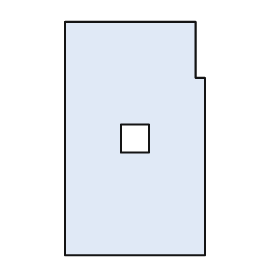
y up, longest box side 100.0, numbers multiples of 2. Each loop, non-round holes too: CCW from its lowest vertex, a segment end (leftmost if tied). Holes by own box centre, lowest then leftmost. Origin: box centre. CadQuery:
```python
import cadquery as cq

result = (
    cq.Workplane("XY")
    .moveTo(-30.0, -50.0)
    .lineTo(30.0, -50.0)
    .lineTo(30.0, 26.0)
    .lineTo(26.0, 26.0)
    .lineTo(26.0, 50.0)
    .lineTo(-30.0, 50.0)
    .close()
    .moveTo(-6.0, -6.0)
    .lineTo(6.0, -6.0)
    .lineTo(6.0, 6.0)
    .lineTo(-6.0, 6.0)
    .close()
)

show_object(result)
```